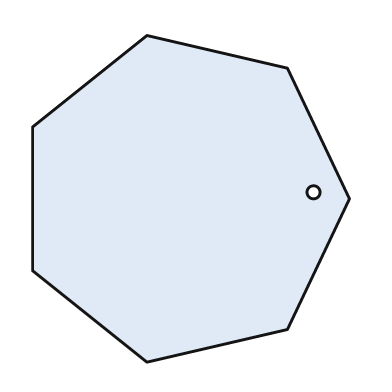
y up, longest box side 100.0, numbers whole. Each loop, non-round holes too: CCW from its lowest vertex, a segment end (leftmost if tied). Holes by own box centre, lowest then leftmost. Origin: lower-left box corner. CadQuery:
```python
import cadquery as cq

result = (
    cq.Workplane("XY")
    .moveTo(35.0, 0.0)
    .lineTo(78.0, 10.0)
    .lineTo(97.0, 50.0)
    .lineTo(78.0, 90.0)
    .lineTo(35.0, 100.0)
    .lineTo(0.0, 72.0)
    .lineTo(0.0, 28.0)
    .close()
    .moveTo(86.0, 52.0)
    .circle(2.0)
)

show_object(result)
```